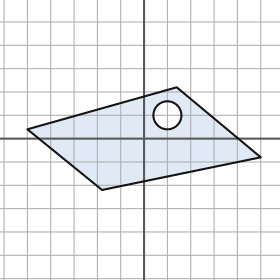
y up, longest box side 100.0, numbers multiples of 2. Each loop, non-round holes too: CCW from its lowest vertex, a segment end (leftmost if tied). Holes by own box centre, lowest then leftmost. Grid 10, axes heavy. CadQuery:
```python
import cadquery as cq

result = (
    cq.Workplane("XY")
    .moveTo(-18.0, -22.0)
    .lineTo(50.0, -8.0)
    .lineTo(14.0, 22.0)
    .lineTo(-50.0, 4.0)
    .close()
    .moveTo(10.0, 10.0)
    .circle(6.0)
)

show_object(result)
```